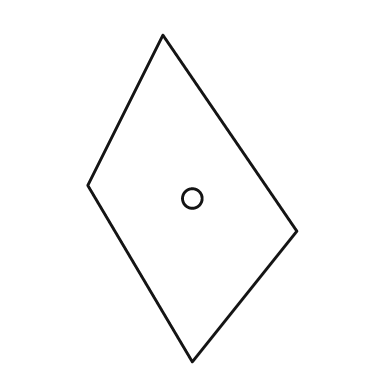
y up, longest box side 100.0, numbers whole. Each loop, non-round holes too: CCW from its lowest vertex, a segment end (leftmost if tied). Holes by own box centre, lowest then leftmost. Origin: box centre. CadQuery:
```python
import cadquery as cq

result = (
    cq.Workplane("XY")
    .moveTo(0.0, -50.0)
    .lineTo(32.0, -10.0)
    .lineTo(-9.0, 50.0)
    .lineTo(-32.0, 4.0)
    .close()
    .moveTo(0.0, 0.0)
    .circle(3.0)
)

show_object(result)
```